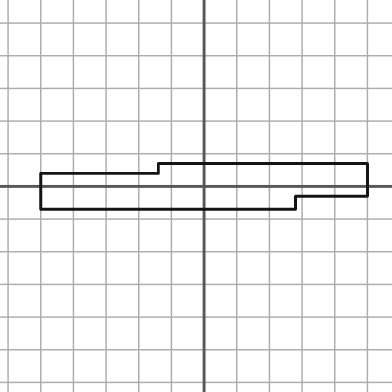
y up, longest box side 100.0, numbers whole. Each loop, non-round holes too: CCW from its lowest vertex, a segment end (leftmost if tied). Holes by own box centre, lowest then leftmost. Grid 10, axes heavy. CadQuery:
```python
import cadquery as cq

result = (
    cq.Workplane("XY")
    .moveTo(-50.0, -7.0)
    .lineTo(28.0, -7.0)
    .lineTo(28.0, -3.0)
    .lineTo(50.0, -3.0)
    .lineTo(50.0, 7.0)
    .lineTo(-14.0, 7.0)
    .lineTo(-14.0, 4.0)
    .lineTo(-50.0, 4.0)
    .close()
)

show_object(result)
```